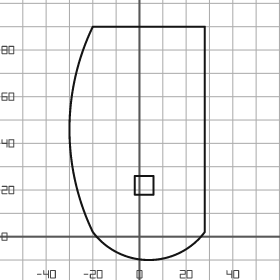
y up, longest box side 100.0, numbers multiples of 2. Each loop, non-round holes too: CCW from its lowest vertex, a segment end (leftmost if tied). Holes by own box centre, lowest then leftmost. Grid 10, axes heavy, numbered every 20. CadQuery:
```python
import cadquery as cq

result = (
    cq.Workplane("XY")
    .moveTo(-20.0, 2.0)
    .threePointArc((4.0, -10.0), (28.0, 2.0))
    .lineTo(28.0, 90.0)
    .lineTo(-20.0, 90.0)
    .threePointArc((-30.0, 46.0), (-20.0, 2.0))
    .close()
    .moveTo(-2.0, 18.0)
    .lineTo(6.0, 18.0)
    .lineTo(6.0, 26.0)
    .lineTo(-2.0, 26.0)
    .close()
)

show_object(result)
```